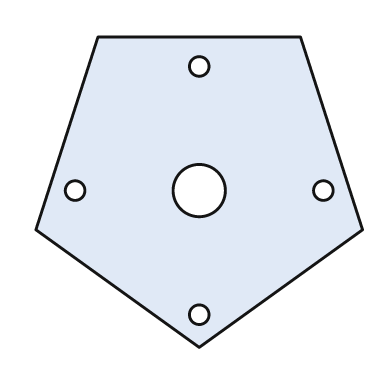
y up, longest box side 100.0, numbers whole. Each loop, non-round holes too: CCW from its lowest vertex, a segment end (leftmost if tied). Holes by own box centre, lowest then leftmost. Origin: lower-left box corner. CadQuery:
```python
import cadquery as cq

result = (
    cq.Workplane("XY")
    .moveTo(50.0, 0.0)
    .lineTo(100.0, 36.0)
    .lineTo(81.0, 95.0)
    .lineTo(19.0, 95.0)
    .lineTo(0.0, 36.0)
    .close()
    .moveTo(50.0, 10.0)
    .circle(3.0)
    .moveTo(12.0, 48.0)
    .circle(3.0)
    .moveTo(50.0, 48.0)
    .circle(8.0)
    .moveTo(88.0, 48.0)
    .circle(3.0)
    .moveTo(50.0, 86.0)
    .circle(3.0)
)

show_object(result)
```